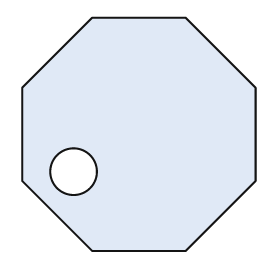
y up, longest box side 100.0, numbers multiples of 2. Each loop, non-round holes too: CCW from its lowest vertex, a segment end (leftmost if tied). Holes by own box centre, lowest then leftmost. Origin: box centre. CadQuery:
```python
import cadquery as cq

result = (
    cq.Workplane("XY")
    .moveTo(-20.0, -50.0)
    .lineTo(20.0, -50.0)
    .lineTo(50.0, -20.0)
    .lineTo(50.0, 20.0)
    .lineTo(20.0, 50.0)
    .lineTo(-20.0, 50.0)
    .lineTo(-50.0, 20.0)
    .lineTo(-50.0, -20.0)
    .close()
    .moveTo(-28.0, -16.0)
    .circle(10.0)
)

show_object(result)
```